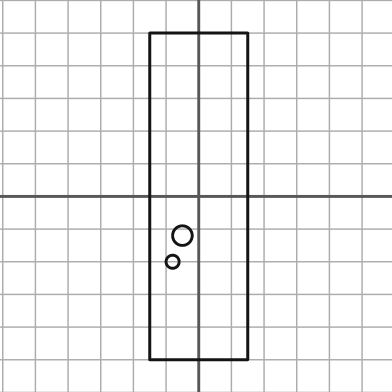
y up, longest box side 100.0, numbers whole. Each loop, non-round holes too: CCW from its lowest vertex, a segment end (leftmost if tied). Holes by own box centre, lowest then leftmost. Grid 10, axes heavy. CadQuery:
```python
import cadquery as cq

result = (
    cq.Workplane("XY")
    .moveTo(-15.0, -50.0)
    .lineTo(15.0, -50.0)
    .lineTo(15.0, 50.0)
    .lineTo(-15.0, 50.0)
    .close()
    .moveTo(-8.0, -20.0)
    .circle(2.0)
    .moveTo(-5.0, -12.0)
    .circle(3.0)
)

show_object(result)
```